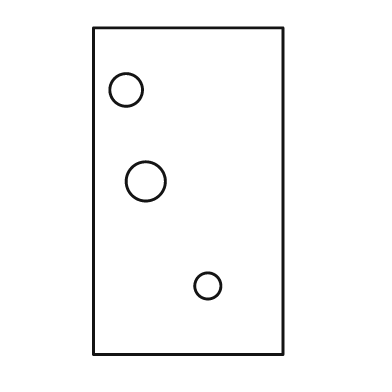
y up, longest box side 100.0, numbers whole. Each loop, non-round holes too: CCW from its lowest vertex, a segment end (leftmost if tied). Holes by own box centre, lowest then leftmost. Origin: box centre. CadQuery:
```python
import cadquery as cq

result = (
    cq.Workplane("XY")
    .moveTo(-29.0, -50.0)
    .lineTo(29.0, -50.0)
    .lineTo(29.0, 50.0)
    .lineTo(-29.0, 50.0)
    .close()
    .moveTo(6.0, -29.0)
    .circle(4.0)
    .moveTo(-13.0, 3.0)
    .circle(6.0)
    .moveTo(-19.0, 31.0)
    .circle(5.0)
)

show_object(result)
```